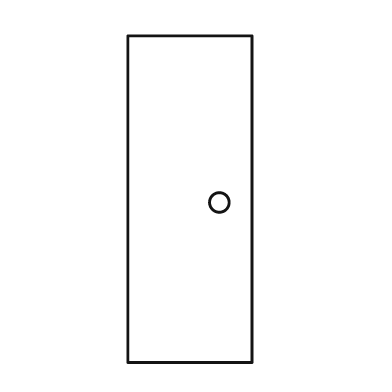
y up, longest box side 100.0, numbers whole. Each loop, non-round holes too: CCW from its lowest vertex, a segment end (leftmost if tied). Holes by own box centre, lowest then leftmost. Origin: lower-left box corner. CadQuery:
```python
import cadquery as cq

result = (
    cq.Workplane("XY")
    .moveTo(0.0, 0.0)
    .lineTo(38.0, 0.0)
    .lineTo(38.0, 100.0)
    .lineTo(0.0, 100.0)
    .close()
    .moveTo(28.0, 49.0)
    .circle(3.0)
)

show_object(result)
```